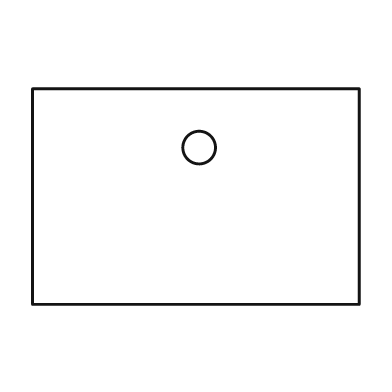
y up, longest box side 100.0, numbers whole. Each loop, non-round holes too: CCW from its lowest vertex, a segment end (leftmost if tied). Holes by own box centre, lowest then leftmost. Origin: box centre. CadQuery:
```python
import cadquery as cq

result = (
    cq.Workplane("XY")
    .moveTo(-50.0, -33.0)
    .lineTo(50.0, -33.0)
    .lineTo(50.0, 33.0)
    .lineTo(-50.0, 33.0)
    .close()
    .moveTo(1.0, 15.0)
    .circle(5.0)
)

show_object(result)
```